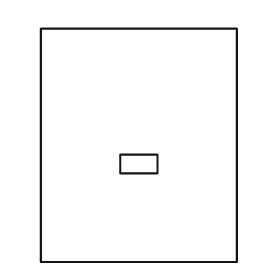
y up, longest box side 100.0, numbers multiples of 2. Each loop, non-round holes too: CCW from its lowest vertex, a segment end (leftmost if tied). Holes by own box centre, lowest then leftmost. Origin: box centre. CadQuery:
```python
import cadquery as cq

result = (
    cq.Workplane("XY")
    .moveTo(-42.0, -50.0)
    .lineTo(42.0, -50.0)
    .lineTo(42.0, 50.0)
    .lineTo(-42.0, 50.0)
    .close()
    .moveTo(-8.0, -12.0)
    .lineTo(8.0, -12.0)
    .lineTo(8.0, -4.0)
    .lineTo(-8.0, -4.0)
    .close()
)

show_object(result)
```